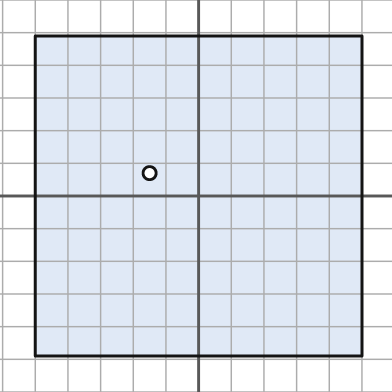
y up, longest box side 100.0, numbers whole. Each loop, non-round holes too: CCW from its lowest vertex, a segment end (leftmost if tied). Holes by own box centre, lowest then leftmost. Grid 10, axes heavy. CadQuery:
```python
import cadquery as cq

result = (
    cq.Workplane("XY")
    .moveTo(-50.0, -49.0)
    .lineTo(50.0, -49.0)
    .lineTo(50.0, 49.0)
    .lineTo(-50.0, 49.0)
    .close()
    .moveTo(-15.0, 7.0)
    .circle(2.0)
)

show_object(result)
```